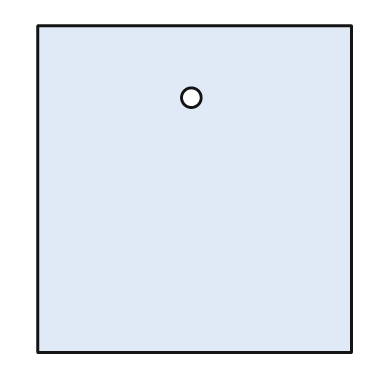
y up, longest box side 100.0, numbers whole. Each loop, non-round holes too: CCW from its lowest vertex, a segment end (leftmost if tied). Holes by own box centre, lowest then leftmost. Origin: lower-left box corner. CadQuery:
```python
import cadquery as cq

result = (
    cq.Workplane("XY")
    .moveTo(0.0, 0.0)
    .lineTo(96.0, 0.0)
    .lineTo(96.0, 100.0)
    .lineTo(0.0, 100.0)
    .close()
    .moveTo(47.0, 78.0)
    .circle(3.0)
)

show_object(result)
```